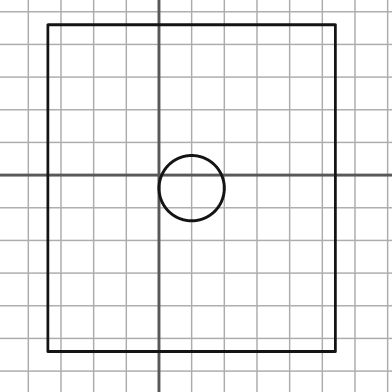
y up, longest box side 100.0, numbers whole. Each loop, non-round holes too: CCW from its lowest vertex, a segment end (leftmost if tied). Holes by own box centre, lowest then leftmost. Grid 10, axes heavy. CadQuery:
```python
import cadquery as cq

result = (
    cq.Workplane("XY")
    .moveTo(-34.0, -54.0)
    .lineTo(54.0, -54.0)
    .lineTo(54.0, 46.0)
    .lineTo(-34.0, 46.0)
    .close()
    .moveTo(10.0, -4.0)
    .circle(10.0)
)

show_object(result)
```